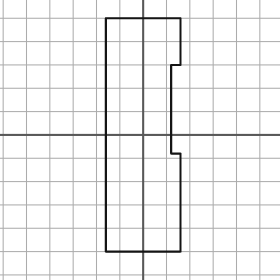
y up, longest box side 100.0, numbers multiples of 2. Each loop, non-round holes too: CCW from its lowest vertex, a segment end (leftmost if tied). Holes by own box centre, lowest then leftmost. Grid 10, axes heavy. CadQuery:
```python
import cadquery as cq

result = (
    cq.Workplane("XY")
    .moveTo(-16.0, -50.0)
    .lineTo(16.0, -50.0)
    .lineTo(16.0, -8.0)
    .lineTo(12.0, -8.0)
    .lineTo(12.0, 30.0)
    .lineTo(16.0, 30.0)
    .lineTo(16.0, 50.0)
    .lineTo(-16.0, 50.0)
    .close()
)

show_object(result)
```